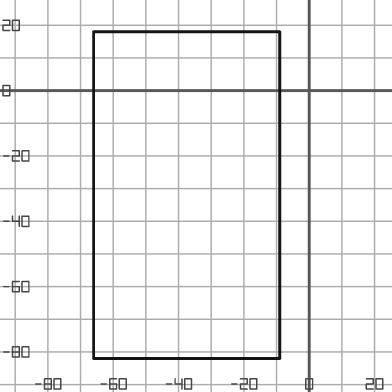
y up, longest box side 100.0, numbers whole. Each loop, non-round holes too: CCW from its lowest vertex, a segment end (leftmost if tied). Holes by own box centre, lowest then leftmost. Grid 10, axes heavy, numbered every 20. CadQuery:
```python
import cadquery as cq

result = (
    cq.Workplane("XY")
    .moveTo(-66.0, -82.0)
    .lineTo(-9.0, -82.0)
    .lineTo(-9.0, 18.0)
    .lineTo(-66.0, 18.0)
    .close()
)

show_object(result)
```